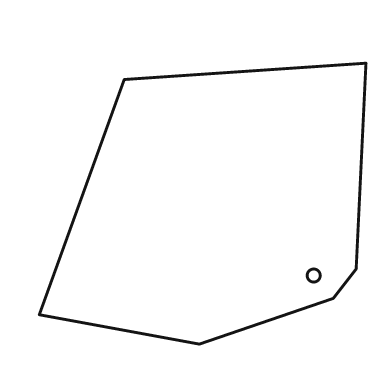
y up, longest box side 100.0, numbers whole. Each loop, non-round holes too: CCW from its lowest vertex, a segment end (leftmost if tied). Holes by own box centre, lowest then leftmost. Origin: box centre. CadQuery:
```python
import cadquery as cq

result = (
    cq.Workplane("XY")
    .moveTo(-1.0, -43.0)
    .lineTo(40.0, -29.0)
    .lineTo(47.0, -20.0)
    .lineTo(50.0, 43.0)
    .lineTo(-24.0, 38.0)
    .lineTo(-50.0, -34.0)
    .close()
    .moveTo(34.0, -22.0)
    .circle(2.0)
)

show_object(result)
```